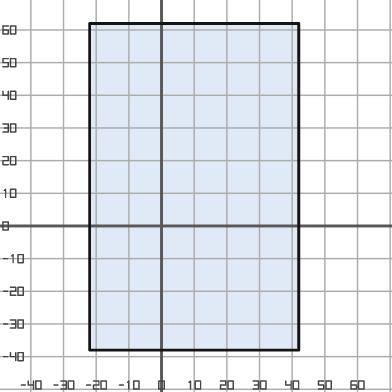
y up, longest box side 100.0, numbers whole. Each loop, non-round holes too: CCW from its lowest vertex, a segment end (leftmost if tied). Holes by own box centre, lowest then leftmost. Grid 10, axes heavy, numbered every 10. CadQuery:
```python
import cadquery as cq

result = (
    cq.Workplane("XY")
    .moveTo(-22.0, -38.0)
    .lineTo(42.0, -38.0)
    .lineTo(42.0, 62.0)
    .lineTo(-22.0, 62.0)
    .close()
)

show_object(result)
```